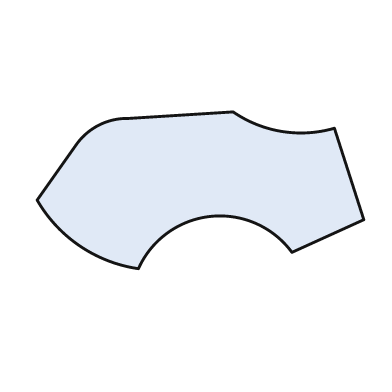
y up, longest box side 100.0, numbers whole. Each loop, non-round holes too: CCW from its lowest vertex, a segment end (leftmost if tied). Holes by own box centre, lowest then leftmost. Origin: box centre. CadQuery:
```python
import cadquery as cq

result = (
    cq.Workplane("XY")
    .moveTo(-19.0, -24.0)
    .threePointArc((3.0, -8.0), (28.0, -19.0))
    .lineTo(50.0, -9.0)
    .lineTo(41.0, 19.0)
    .threePointArc((25.0, 18.0), (10.0, 24.0))
    .lineTo(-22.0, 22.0)
    .threePointArc((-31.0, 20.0), (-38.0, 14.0))
    .lineTo(-50.0, -3.0)
    .threePointArc((-37.0, -17.0), (-19.0, -24.0))
    .close()
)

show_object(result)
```